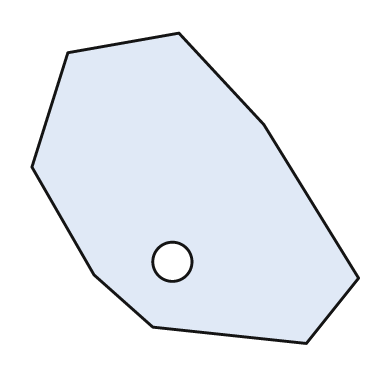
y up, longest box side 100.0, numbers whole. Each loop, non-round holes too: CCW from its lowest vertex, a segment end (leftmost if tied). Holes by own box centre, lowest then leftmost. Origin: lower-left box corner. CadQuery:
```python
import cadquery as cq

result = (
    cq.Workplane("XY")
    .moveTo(84.0, 0.0)
    .lineTo(100.0, 20.0)
    .lineTo(71.0, 67.0)
    .lineTo(45.0, 95.0)
    .lineTo(11.0, 89.0)
    .lineTo(0.0, 54.0)
    .lineTo(19.0, 21.0)
    .lineTo(37.0, 5.0)
    .close()
    .moveTo(43.0, 25.0)
    .circle(6.0)
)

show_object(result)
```